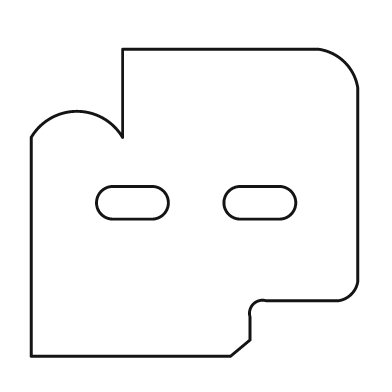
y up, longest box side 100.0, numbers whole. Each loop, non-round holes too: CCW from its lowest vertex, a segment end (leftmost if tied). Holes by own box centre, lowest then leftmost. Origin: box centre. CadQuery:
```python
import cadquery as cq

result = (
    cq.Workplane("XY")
    .moveTo(-50.0, -47.0)
    .lineTo(11.0, -47.0)
    .lineTo(17.0, -42.0)
    .lineTo(17.0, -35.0)
    .threePointArc((18.0, -31.0), (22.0, -30.0))
    .lineTo(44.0, -30.0)
    .threePointArc((48.0, -28.0), (50.0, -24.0))
    .lineTo(50.0, 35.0)
    .threePointArc((46.0, 43.0), (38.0, 47.0))
    .lineTo(-22.0, 47.0)
    .lineTo(-22.0, 20.0)
    .threePointArc((-36.0, 28.0), (-50.0, 20.0))
    .close()
    .moveTo(-25.0, -5.0)
    .lineTo(-13.0, -5.0)
    .threePointArc((-8.0, 0.0), (-13.0, 5.0))
    .lineTo(-25.0, 5.0)
    .threePointArc((-30.0, 0.0), (-25.0, -5.0))
    .close()
    .moveTo(14.0, -5.0)
    .lineTo(26.0, -5.0)
    .threePointArc((31.0, 0.0), (26.0, 5.0))
    .lineTo(14.0, 5.0)
    .threePointArc((9.0, 0.0), (14.0, -5.0))
    .close()
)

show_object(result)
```